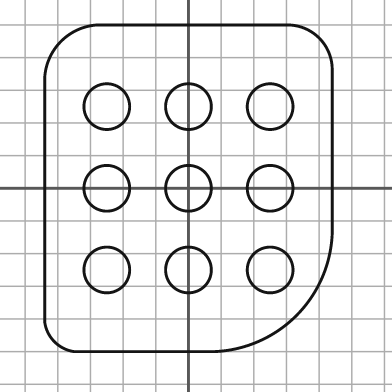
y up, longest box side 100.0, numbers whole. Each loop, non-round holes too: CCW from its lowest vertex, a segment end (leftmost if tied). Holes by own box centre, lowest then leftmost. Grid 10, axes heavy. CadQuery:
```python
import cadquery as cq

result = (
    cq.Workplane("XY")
    .moveTo(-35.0, -50.0)
    .lineTo(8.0, -50.0)
    .threePointArc((33.0, -39.0), (44.0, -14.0))
    .lineTo(44.0, 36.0)
    .threePointArc((40.0, 46.0), (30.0, 50.0))
    .lineTo(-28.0, 50.0)
    .threePointArc((-39.0, 45.0), (-44.0, 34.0))
    .lineTo(-44.0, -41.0)
    .threePointArc((-41.0, -47.0), (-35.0, -50.0))
    .close()
    .moveTo(-25.0, -25.0)
    .circle(7.0)
    .moveTo(0.0, -25.0)
    .circle(7.0)
    .moveTo(25.0, -25.0)
    .circle(7.0)
    .moveTo(-25.0, 0.0)
    .circle(7.0)
    .moveTo(0.0, 0.0)
    .circle(7.0)
    .moveTo(25.0, 0.0)
    .circle(7.0)
    .moveTo(-25.0, 25.0)
    .circle(7.0)
    .moveTo(0.0, 25.0)
    .circle(7.0)
    .moveTo(25.0, 25.0)
    .circle(7.0)
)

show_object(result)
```